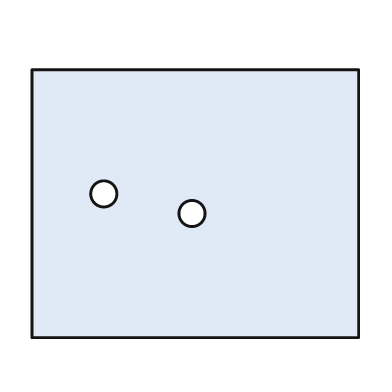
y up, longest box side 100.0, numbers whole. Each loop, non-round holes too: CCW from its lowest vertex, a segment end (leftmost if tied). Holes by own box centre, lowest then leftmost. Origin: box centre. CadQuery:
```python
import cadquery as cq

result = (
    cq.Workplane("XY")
    .moveTo(-50.0, -41.0)
    .lineTo(50.0, -41.0)
    .lineTo(50.0, 41.0)
    .lineTo(-50.0, 41.0)
    .close()
    .moveTo(-1.0, -3.0)
    .circle(4.0)
    .moveTo(-28.0, 3.0)
    .circle(4.0)
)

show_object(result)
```